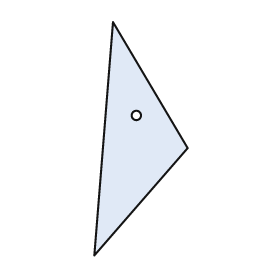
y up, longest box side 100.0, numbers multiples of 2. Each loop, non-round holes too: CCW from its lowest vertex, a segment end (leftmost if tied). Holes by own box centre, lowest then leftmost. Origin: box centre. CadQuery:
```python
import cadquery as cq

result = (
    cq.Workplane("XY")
    .moveTo(-20.0, -50.0)
    .lineTo(20.0, -4.0)
    .lineTo(-12.0, 50.0)
    .close()
    .moveTo(-2.0, 10.0)
    .circle(2.0)
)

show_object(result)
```